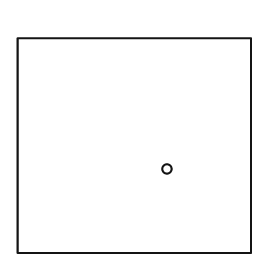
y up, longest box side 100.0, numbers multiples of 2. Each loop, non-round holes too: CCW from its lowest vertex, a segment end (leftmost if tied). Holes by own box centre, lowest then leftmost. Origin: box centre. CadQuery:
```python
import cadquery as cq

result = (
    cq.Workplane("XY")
    .moveTo(-50.0, -46.0)
    .lineTo(50.0, -46.0)
    .lineTo(50.0, 46.0)
    .lineTo(-50.0, 46.0)
    .close()
    .moveTo(14.0, -10.0)
    .circle(2.0)
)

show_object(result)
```